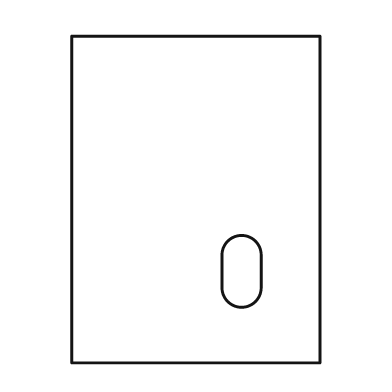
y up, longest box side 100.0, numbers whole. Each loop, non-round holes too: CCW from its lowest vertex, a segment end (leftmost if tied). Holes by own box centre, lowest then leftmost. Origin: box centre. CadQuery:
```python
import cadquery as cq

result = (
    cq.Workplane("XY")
    .moveTo(-38.0, -50.0)
    .lineTo(38.0, -50.0)
    .lineTo(38.0, 50.0)
    .lineTo(-38.0, 50.0)
    .close()
    .moveTo(8.0, -27.0)
    .threePointArc((14.0, -33.0), (20.0, -27.0))
    .lineTo(20.0, -17.0)
    .threePointArc((14.0, -11.0), (8.0, -17.0))
    .close()
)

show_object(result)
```